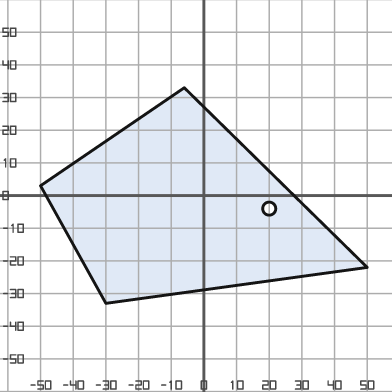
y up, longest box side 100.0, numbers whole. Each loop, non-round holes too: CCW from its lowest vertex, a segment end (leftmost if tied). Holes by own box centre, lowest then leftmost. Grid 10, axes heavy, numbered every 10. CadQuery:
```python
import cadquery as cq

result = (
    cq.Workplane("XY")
    .moveTo(-30.0, -33.0)
    .lineTo(50.0, -22.0)
    .lineTo(-6.0, 33.0)
    .lineTo(-50.0, 3.0)
    .close()
    .moveTo(20.0, -4.0)
    .circle(2.0)
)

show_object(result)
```